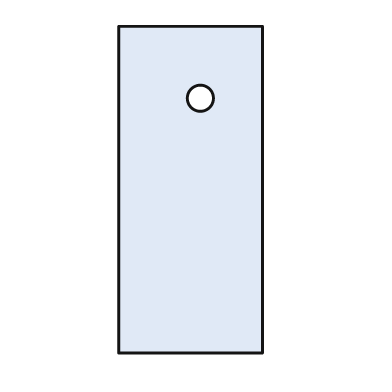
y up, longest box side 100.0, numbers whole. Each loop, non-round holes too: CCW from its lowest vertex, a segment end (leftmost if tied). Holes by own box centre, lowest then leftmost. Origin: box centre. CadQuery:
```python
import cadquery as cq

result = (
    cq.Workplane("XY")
    .moveTo(-22.0, -50.0)
    .lineTo(22.0, -50.0)
    .lineTo(22.0, 50.0)
    .lineTo(-22.0, 50.0)
    .close()
    .moveTo(3.0, 28.0)
    .circle(4.0)
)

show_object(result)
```